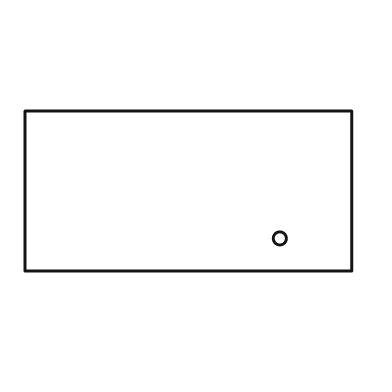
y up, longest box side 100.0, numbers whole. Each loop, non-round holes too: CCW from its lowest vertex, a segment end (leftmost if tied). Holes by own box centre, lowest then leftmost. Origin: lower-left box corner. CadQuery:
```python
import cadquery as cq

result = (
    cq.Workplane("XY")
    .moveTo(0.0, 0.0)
    .lineTo(100.0, 0.0)
    .lineTo(100.0, 49.0)
    .lineTo(0.0, 49.0)
    .close()
    .moveTo(78.0, 10.0)
    .circle(2.0)
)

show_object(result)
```